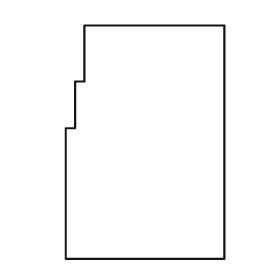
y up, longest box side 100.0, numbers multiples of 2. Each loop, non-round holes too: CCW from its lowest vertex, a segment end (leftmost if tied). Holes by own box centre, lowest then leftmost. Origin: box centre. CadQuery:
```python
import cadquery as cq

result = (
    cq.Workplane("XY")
    .moveTo(-34.0, -50.0)
    .lineTo(34.0, -50.0)
    .lineTo(34.0, 50.0)
    .lineTo(-26.0, 50.0)
    .lineTo(-26.0, 26.0)
    .lineTo(-30.0, 26.0)
    .lineTo(-30.0, 6.0)
    .lineTo(-34.0, 6.0)
    .close()
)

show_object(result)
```